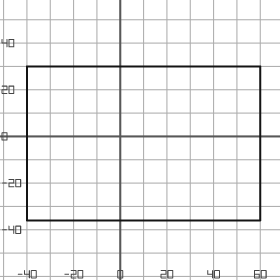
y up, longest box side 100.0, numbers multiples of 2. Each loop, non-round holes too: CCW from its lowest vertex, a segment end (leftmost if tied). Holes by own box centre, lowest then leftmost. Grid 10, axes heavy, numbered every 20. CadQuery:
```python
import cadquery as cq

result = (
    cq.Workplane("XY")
    .moveTo(-40.0, -36.0)
    .lineTo(60.0, -36.0)
    .lineTo(60.0, 30.0)
    .lineTo(-40.0, 30.0)
    .close()
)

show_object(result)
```